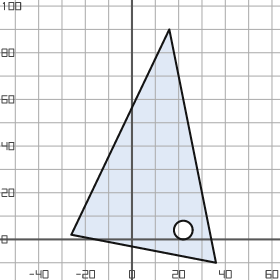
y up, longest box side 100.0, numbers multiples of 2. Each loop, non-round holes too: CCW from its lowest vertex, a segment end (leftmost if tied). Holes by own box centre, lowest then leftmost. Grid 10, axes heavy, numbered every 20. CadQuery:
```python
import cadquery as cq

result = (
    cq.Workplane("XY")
    .moveTo(36.0, -10.0)
    .lineTo(16.0, 90.0)
    .lineTo(-26.0, 2.0)
    .close()
    .moveTo(22.0, 4.0)
    .circle(4.0)
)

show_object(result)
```